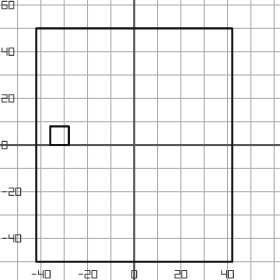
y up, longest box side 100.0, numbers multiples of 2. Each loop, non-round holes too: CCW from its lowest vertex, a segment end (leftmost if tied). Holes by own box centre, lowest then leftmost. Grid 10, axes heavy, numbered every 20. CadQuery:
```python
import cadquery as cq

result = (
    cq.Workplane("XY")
    .moveTo(-42.0, -50.0)
    .lineTo(42.0, -50.0)
    .lineTo(42.0, 50.0)
    .lineTo(-42.0, 50.0)
    .close()
    .moveTo(-36.0, 0.0)
    .lineTo(-28.0, 0.0)
    .lineTo(-28.0, 8.0)
    .lineTo(-36.0, 8.0)
    .close()
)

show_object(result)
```